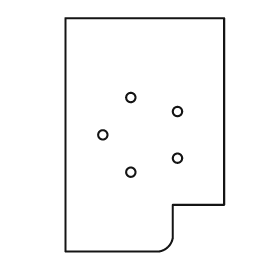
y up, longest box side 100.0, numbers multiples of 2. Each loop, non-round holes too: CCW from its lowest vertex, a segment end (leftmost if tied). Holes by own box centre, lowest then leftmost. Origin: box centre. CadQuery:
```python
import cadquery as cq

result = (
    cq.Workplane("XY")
    .moveTo(-34.0, -50.0)
    .lineTo(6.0, -50.0)
    .threePointArc((10.0, -48.0), (12.0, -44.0))
    .lineTo(12.0, -30.0)
    .lineTo(34.0, -30.0)
    .lineTo(34.0, 50.0)
    .lineTo(-34.0, 50.0)
    .close()
    .moveTo(-6.0, -16.0)
    .circle(2.0)
    .moveTo(14.0, -10.0)
    .circle(2.0)
    .moveTo(-18.0, 0.0)
    .circle(2.0)
    .moveTo(14.0, 10.0)
    .circle(2.0)
    .moveTo(-6.0, 16.0)
    .circle(2.0)
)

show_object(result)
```